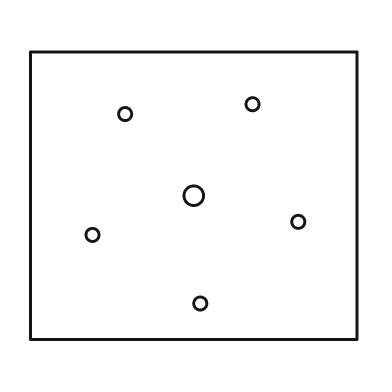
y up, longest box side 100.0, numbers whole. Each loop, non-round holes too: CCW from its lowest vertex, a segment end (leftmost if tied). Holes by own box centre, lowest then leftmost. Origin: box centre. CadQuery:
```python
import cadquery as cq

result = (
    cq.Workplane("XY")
    .moveTo(-50.0, -44.0)
    .lineTo(50.0, -44.0)
    .lineTo(50.0, 44.0)
    .lineTo(-50.0, 44.0)
    .close()
    .moveTo(2.0, -33.0)
    .circle(2.0)
    .moveTo(-31.0, -12.0)
    .circle(2.0)
    .moveTo(32.0, -8.0)
    .circle(2.0)
    .moveTo(0.0, 0.0)
    .circle(3.0)
    .moveTo(-21.0, 25.0)
    .circle(2.0)
    .moveTo(18.0, 28.0)
    .circle(2.0)
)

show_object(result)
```